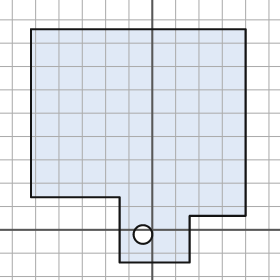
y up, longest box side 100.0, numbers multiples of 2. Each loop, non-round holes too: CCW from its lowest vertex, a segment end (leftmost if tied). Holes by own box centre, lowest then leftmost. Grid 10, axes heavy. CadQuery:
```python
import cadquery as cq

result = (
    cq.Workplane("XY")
    .moveTo(-14.0, -14.0)
    .lineTo(16.0, -14.0)
    .lineTo(16.0, 6.0)
    .lineTo(40.0, 6.0)
    .lineTo(40.0, 86.0)
    .lineTo(-52.0, 86.0)
    .lineTo(-52.0, 14.0)
    .lineTo(-14.0, 14.0)
    .close()
    .moveTo(-4.0, -2.0)
    .circle(4.0)
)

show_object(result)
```